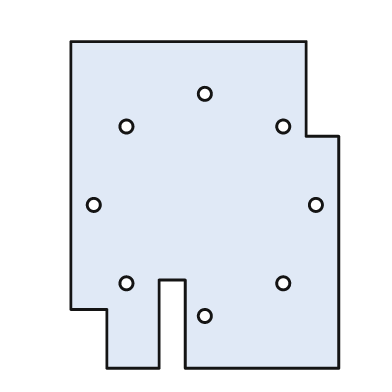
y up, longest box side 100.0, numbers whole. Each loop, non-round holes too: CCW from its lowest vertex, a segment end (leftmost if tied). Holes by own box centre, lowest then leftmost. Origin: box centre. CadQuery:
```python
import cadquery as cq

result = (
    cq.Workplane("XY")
    .moveTo(-30.0, -50.0)
    .lineTo(-14.0, -50.0)
    .lineTo(-14.0, -23.0)
    .lineTo(-6.0, -23.0)
    .lineTo(-6.0, -50.0)
    .lineTo(41.0, -50.0)
    .lineTo(41.0, 21.0)
    .lineTo(31.0, 21.0)
    .lineTo(31.0, 50.0)
    .lineTo(-41.0, 50.0)
    .lineTo(-41.0, -32.0)
    .lineTo(-30.0, -32.0)
    .close()
    .moveTo(0.0, -34.0)
    .circle(2.0)
    .moveTo(-24.0, -24.0)
    .circle(2.0)
    .moveTo(24.0, -24.0)
    .circle(2.0)
    .moveTo(-34.0, 0.0)
    .circle(2.0)
    .moveTo(34.0, 0.0)
    .circle(2.0)
    .moveTo(-24.0, 24.0)
    .circle(2.0)
    .moveTo(24.0, 24.0)
    .circle(2.0)
    .moveTo(0.0, 34.0)
    .circle(2.0)
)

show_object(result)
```